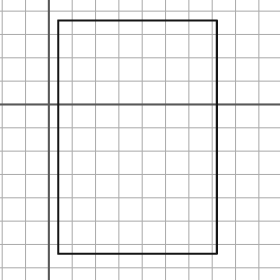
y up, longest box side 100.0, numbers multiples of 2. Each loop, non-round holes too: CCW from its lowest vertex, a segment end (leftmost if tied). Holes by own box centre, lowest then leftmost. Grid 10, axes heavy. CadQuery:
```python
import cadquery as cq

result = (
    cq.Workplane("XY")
    .moveTo(4.0, -64.0)
    .lineTo(72.0, -64.0)
    .lineTo(72.0, 36.0)
    .lineTo(4.0, 36.0)
    .close()
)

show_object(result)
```